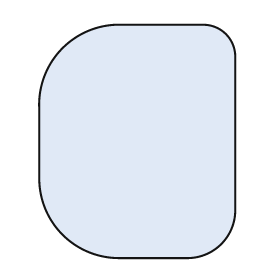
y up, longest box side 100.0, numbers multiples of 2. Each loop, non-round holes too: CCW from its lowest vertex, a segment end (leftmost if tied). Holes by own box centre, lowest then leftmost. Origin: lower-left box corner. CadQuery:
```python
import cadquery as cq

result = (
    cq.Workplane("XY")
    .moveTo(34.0, 0.0)
    .lineTo(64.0, 0.0)
    .threePointArc((78.0, 6.0), (84.0, 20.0))
    .lineTo(84.0, 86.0)
    .threePointArc((80.0, 96.0), (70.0, 100.0))
    .lineTo(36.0, 100.0)
    .threePointArc((10.0, 90.0), (0.0, 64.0))
    .lineTo(0.0, 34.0)
    .threePointArc((10.0, 10.0), (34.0, 0.0))
    .close()
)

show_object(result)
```